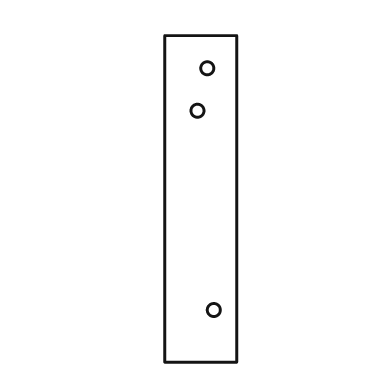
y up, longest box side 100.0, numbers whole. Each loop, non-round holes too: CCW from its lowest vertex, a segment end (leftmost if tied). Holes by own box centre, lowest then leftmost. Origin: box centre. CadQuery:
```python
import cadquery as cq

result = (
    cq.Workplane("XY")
    .moveTo(-11.0, -50.0)
    .lineTo(11.0, -50.0)
    .lineTo(11.0, 50.0)
    .lineTo(-11.0, 50.0)
    .close()
    .moveTo(4.0, -34.0)
    .circle(2.0)
    .moveTo(-1.0, 27.0)
    .circle(2.0)
    .moveTo(2.0, 40.0)
    .circle(2.0)
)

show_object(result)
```